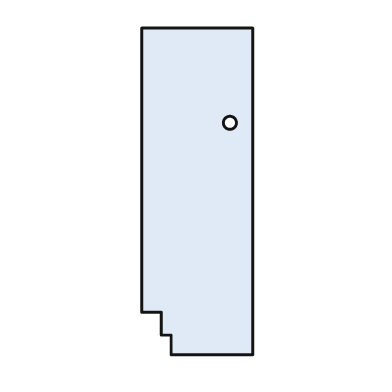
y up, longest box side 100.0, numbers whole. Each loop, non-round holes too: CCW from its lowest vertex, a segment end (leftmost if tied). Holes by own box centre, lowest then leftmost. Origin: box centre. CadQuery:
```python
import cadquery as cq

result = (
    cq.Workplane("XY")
    .moveTo(-8.0, -50.0)
    .lineTo(17.0, -50.0)
    .lineTo(17.0, 50.0)
    .lineTo(-17.0, 50.0)
    .lineTo(-17.0, -37.0)
    .lineTo(-11.0, -37.0)
    .lineTo(-11.0, -44.0)
    .lineTo(-8.0, -44.0)
    .close()
    .moveTo(10.0, 21.0)
    .circle(2.0)
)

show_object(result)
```